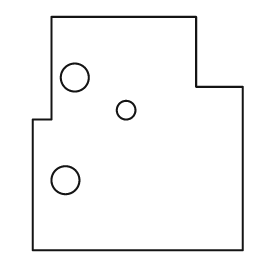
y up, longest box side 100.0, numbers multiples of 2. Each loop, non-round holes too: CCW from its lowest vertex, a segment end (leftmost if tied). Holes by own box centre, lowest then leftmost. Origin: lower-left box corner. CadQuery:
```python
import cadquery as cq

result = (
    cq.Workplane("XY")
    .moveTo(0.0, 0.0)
    .lineTo(90.0, 0.0)
    .lineTo(90.0, 70.0)
    .lineTo(70.0, 70.0)
    .lineTo(70.0, 100.0)
    .lineTo(8.0, 100.0)
    .lineTo(8.0, 56.0)
    .lineTo(0.0, 56.0)
    .close()
    .moveTo(14.0, 30.0)
    .circle(6.0)
    .moveTo(40.0, 60.0)
    .circle(4.0)
    .moveTo(18.0, 74.0)
    .circle(6.0)
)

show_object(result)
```